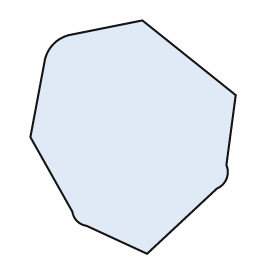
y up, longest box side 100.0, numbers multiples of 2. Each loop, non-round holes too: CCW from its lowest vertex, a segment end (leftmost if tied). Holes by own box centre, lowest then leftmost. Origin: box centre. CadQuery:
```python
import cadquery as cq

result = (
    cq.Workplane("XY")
    .moveTo(6.0, -50.0)
    .lineTo(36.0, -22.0)
    .threePointArc((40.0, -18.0), (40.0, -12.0))
    .lineTo(44.0, 18.0)
    .lineTo(4.0, 50.0)
    .lineTo(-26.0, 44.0)
    .threePointArc((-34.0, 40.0), (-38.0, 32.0))
    .lineTo(-44.0, 0.0)
    .lineTo(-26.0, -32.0)
    .threePointArc((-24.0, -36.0), (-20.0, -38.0))
    .close()
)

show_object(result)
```